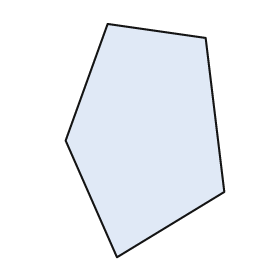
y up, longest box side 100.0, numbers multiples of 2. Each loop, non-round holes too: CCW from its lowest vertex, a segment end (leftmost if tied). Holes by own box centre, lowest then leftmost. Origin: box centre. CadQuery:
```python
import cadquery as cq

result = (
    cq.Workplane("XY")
    .moveTo(-12.0, -50.0)
    .lineTo(34.0, -22.0)
    .lineTo(26.0, 44.0)
    .lineTo(-16.0, 50.0)
    .lineTo(-34.0, 0.0)
    .close()
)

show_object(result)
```